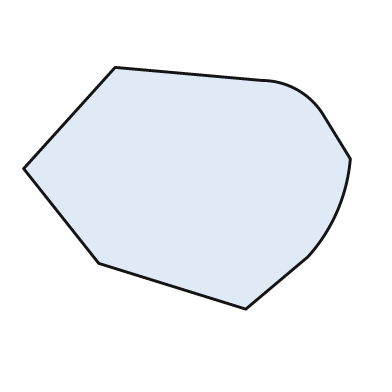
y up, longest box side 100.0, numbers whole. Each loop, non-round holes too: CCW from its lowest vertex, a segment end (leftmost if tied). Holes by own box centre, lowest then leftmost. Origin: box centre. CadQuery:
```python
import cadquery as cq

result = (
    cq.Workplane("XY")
    .moveTo(18.0, -37.0)
    .lineTo(37.0, -21.0)
    .threePointArc((46.0, -7.0), (50.0, 9.0))
    .lineTo(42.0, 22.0)
    .threePointArc((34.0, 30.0), (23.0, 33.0))
    .lineTo(-22.0, 37.0)
    .lineTo(-50.0, 6.0)
    .lineTo(-27.0, -23.0)
    .close()
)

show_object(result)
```